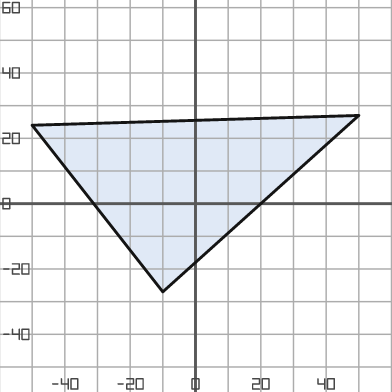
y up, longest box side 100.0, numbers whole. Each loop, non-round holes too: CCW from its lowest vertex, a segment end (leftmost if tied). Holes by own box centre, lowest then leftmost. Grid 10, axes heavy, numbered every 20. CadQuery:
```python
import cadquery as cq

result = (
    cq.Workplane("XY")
    .moveTo(-10.0, -27.0)
    .lineTo(50.0, 27.0)
    .lineTo(-50.0, 24.0)
    .close()
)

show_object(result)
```